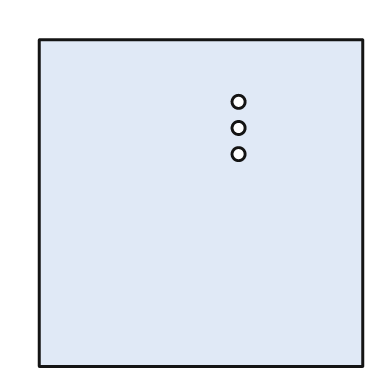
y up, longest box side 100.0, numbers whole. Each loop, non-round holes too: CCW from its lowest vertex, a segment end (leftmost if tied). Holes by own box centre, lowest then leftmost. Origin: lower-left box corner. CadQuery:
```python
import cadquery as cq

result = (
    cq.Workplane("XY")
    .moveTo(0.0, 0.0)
    .lineTo(99.0, 0.0)
    .lineTo(99.0, 100.0)
    .lineTo(0.0, 100.0)
    .close()
    .moveTo(61.0, 65.0)
    .circle(2.0)
    .moveTo(61.0, 73.0)
    .circle(2.0)
    .moveTo(61.0, 81.0)
    .circle(2.0)
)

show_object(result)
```